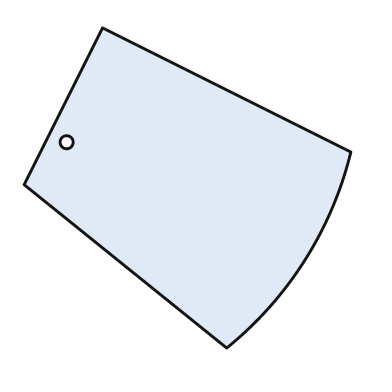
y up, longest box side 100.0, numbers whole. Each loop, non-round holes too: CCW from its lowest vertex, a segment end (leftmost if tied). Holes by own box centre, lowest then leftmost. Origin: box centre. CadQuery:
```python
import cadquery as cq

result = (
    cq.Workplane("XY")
    .moveTo(12.0, -49.0)
    .threePointArc((36.0, -22.0), (50.0, 11.0))
    .lineTo(-26.0, 49.0)
    .lineTo(-50.0, 1.0)
    .close()
    .moveTo(-37.0, 14.0)
    .circle(2.0)
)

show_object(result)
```